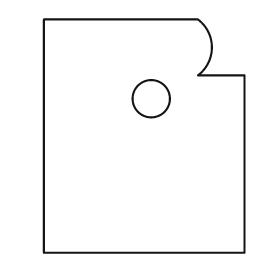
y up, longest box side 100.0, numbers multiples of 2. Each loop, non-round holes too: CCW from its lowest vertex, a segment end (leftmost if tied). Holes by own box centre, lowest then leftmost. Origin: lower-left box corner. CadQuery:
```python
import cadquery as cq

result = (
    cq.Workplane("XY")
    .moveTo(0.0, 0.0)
    .lineTo(86.0, 0.0)
    .lineTo(86.0, 76.0)
    .lineTo(66.0, 76.0)
    .threePointArc((72.0, 88.0), (66.0, 100.0))
    .lineTo(0.0, 100.0)
    .close()
    .moveTo(46.0, 66.0)
    .circle(8.0)
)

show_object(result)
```